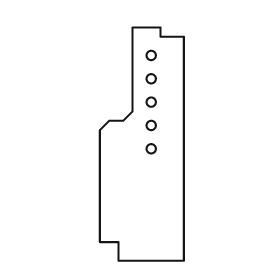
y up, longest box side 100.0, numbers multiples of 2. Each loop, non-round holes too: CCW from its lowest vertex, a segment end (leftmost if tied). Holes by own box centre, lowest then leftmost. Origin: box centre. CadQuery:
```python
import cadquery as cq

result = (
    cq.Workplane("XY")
    .moveTo(-10.0, -50.0)
    .lineTo(18.0, -50.0)
    .lineTo(18.0, 46.0)
    .lineTo(8.0, 46.0)
    .lineTo(8.0, 50.0)
    .lineTo(-4.0, 50.0)
    .lineTo(-4.0, 14.0)
    .lineTo(-8.0, 10.0)
    .lineTo(-14.0, 10.0)
    .lineTo(-18.0, 6.0)
    .lineTo(-18.0, -42.0)
    .lineTo(-10.0, -42.0)
    .close()
    .moveTo(4.0, -2.0)
    .circle(2.0)
    .moveTo(4.0, 8.0)
    .circle(2.0)
    .moveTo(4.0, 18.0)
    .circle(2.0)
    .moveTo(4.0, 28.0)
    .circle(2.0)
    .moveTo(4.0, 38.0)
    .circle(2.0)
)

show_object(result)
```